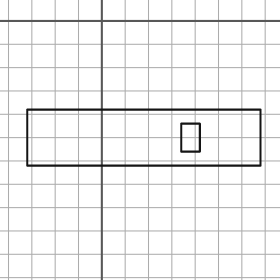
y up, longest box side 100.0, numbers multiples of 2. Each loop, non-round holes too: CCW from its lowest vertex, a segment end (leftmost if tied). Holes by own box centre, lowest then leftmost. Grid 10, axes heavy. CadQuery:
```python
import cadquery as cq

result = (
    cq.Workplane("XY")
    .moveTo(-32.0, -62.0)
    .lineTo(68.0, -62.0)
    .lineTo(68.0, -38.0)
    .lineTo(-32.0, -38.0)
    .close()
    .moveTo(34.0, -56.0)
    .lineTo(42.0, -56.0)
    .lineTo(42.0, -44.0)
    .lineTo(34.0, -44.0)
    .close()
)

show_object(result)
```